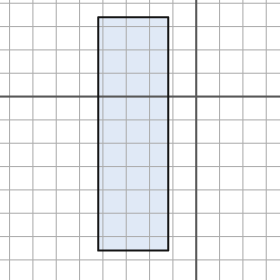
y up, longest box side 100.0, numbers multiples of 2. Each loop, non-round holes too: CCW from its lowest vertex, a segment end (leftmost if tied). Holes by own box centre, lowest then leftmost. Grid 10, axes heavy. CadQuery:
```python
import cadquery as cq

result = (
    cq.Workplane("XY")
    .moveTo(-42.0, -66.0)
    .lineTo(-12.0, -66.0)
    .lineTo(-12.0, 34.0)
    .lineTo(-42.0, 34.0)
    .close()
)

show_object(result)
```